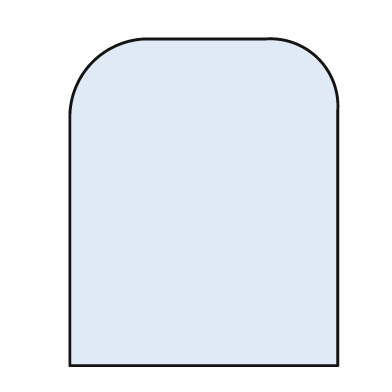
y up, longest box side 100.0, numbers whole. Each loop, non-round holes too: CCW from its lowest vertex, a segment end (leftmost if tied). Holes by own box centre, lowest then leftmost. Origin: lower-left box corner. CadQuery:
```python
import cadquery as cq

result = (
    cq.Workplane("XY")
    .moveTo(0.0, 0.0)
    .lineTo(82.0, 0.0)
    .lineTo(82.0, 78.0)
    .threePointArc((76.0, 94.0), (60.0, 100.0))
    .lineTo(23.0, 100.0)
    .threePointArc((7.0, 93.0), (0.0, 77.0))
    .close()
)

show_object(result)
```